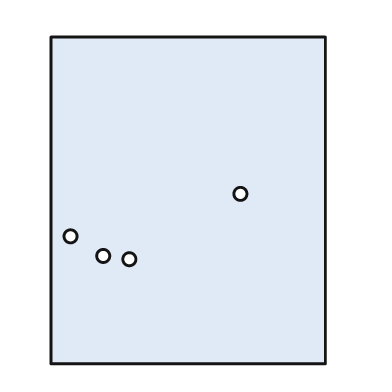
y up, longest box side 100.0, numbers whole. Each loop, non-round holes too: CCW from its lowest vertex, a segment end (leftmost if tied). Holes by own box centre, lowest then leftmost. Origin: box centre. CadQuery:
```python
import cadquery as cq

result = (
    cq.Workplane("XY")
    .moveTo(-42.0, -50.0)
    .lineTo(42.0, -50.0)
    .lineTo(42.0, 50.0)
    .lineTo(-42.0, 50.0)
    .close()
    .moveTo(-18.0, -18.0)
    .circle(2.0)
    .moveTo(-26.0, -17.0)
    .circle(2.0)
    .moveTo(-36.0, -11.0)
    .circle(2.0)
    .moveTo(16.0, 2.0)
    .circle(2.0)
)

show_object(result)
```